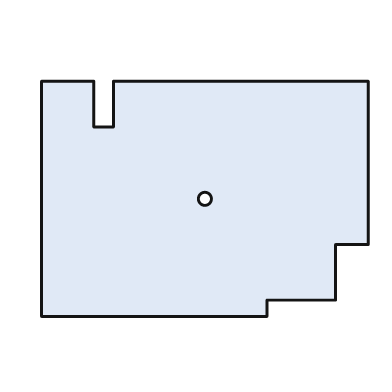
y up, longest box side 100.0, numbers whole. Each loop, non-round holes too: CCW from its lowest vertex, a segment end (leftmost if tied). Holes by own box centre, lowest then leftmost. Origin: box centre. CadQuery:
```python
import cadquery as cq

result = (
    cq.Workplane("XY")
    .moveTo(-50.0, -36.0)
    .lineTo(19.0, -36.0)
    .lineTo(19.0, -31.0)
    .lineTo(40.0, -31.0)
    .lineTo(40.0, -14.0)
    .lineTo(50.0, -14.0)
    .lineTo(50.0, 36.0)
    .lineTo(-28.0, 36.0)
    .lineTo(-28.0, 22.0)
    .lineTo(-34.0, 22.0)
    .lineTo(-34.0, 36.0)
    .lineTo(-50.0, 36.0)
    .close()
    .moveTo(0.0, 0.0)
    .circle(2.0)
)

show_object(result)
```